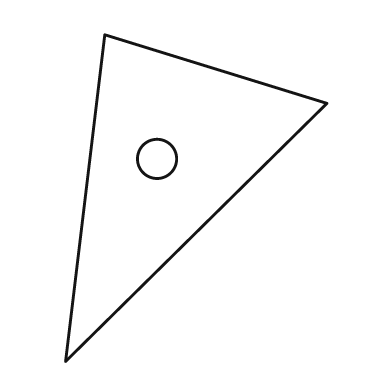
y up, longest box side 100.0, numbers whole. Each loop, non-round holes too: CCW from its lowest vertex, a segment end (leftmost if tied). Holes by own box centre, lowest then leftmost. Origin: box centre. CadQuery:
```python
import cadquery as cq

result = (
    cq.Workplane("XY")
    .moveTo(-40.0, -50.0)
    .lineTo(40.0, 29.0)
    .lineTo(-28.0, 50.0)
    .close()
    .moveTo(-12.0, 12.0)
    .circle(6.0)
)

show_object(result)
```